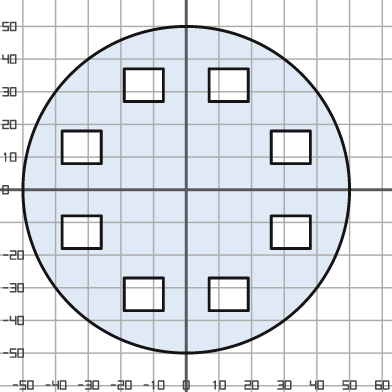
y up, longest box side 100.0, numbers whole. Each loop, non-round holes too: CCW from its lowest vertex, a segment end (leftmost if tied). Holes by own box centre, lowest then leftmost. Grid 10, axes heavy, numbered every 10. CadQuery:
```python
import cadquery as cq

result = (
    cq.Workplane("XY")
    .moveTo(0.0, 0.0)
    .circle(50.0)
    .moveTo(-19.0, -37.0)
    .lineTo(-7.0, -37.0)
    .lineTo(-7.0, -27.0)
    .lineTo(-19.0, -27.0)
    .close()
    .moveTo(7.0, -37.0)
    .lineTo(19.0, -37.0)
    .lineTo(19.0, -27.0)
    .lineTo(7.0, -27.0)
    .close()
    .moveTo(-38.0, -18.0)
    .lineTo(-26.0, -18.0)
    .lineTo(-26.0, -8.0)
    .lineTo(-38.0, -8.0)
    .close()
    .moveTo(26.0, -18.0)
    .lineTo(38.0, -18.0)
    .lineTo(38.0, -8.0)
    .lineTo(26.0, -8.0)
    .close()
    .moveTo(-38.0, 8.0)
    .lineTo(-26.0, 8.0)
    .lineTo(-26.0, 18.0)
    .lineTo(-38.0, 18.0)
    .close()
    .moveTo(26.0, 8.0)
    .lineTo(38.0, 8.0)
    .lineTo(38.0, 18.0)
    .lineTo(26.0, 18.0)
    .close()
    .moveTo(-19.0, 27.0)
    .lineTo(-7.0, 27.0)
    .lineTo(-7.0, 37.0)
    .lineTo(-19.0, 37.0)
    .close()
    .moveTo(7.0, 27.0)
    .lineTo(19.0, 27.0)
    .lineTo(19.0, 37.0)
    .lineTo(7.0, 37.0)
    .close()
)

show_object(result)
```